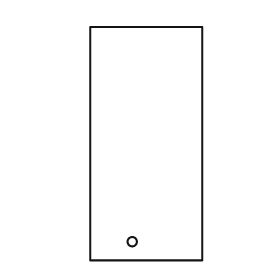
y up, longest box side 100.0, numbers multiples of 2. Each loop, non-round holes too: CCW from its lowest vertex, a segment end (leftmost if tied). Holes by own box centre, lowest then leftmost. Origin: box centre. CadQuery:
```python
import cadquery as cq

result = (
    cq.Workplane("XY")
    .moveTo(-24.0, -50.0)
    .lineTo(24.0, -50.0)
    .lineTo(24.0, 50.0)
    .lineTo(-24.0, 50.0)
    .close()
    .moveTo(-6.0, -42.0)
    .circle(2.0)
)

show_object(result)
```